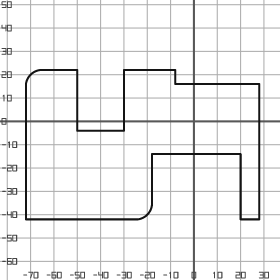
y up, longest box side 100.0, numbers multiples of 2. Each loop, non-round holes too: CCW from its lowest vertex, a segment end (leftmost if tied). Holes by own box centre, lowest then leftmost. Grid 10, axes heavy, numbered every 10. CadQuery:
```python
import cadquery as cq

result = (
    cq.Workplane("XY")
    .moveTo(-72.0, -42.0)
    .lineTo(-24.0, -42.0)
    .threePointArc((-20.0, -40.0), (-18.0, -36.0))
    .lineTo(-18.0, -14.0)
    .lineTo(20.0, -14.0)
    .lineTo(20.0, -42.0)
    .lineTo(28.0, -42.0)
    .lineTo(28.0, 16.0)
    .lineTo(-8.0, 16.0)
    .lineTo(-8.0, 22.0)
    .lineTo(-30.0, 22.0)
    .lineTo(-30.0, -4.0)
    .lineTo(-50.0, -4.0)
    .lineTo(-50.0, 22.0)
    .lineTo(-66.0, 22.0)
    .threePointArc((-70.0, 20.0), (-72.0, 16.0))
    .close()
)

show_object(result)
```